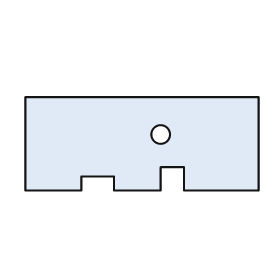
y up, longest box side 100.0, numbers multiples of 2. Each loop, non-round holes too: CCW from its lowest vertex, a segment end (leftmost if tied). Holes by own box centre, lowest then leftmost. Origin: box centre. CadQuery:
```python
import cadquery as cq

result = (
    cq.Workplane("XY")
    .moveTo(-50.0, -20.0)
    .lineTo(-26.0, -20.0)
    .lineTo(-26.0, -14.0)
    .lineTo(-12.0, -14.0)
    .lineTo(-12.0, -20.0)
    .lineTo(8.0, -20.0)
    .lineTo(8.0, -10.0)
    .lineTo(18.0, -10.0)
    .lineTo(18.0, -20.0)
    .lineTo(50.0, -20.0)
    .lineTo(50.0, 20.0)
    .lineTo(-50.0, 20.0)
    .close()
    .moveTo(8.0, 4.0)
    .circle(4.0)
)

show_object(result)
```